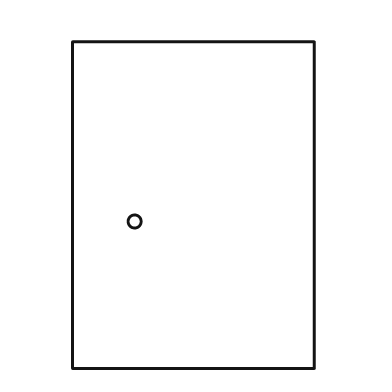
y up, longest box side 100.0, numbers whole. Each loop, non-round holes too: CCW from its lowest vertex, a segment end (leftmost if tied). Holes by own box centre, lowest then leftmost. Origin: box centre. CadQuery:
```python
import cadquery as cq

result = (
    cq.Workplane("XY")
    .moveTo(-37.0, -50.0)
    .lineTo(37.0, -50.0)
    .lineTo(37.0, 50.0)
    .lineTo(-37.0, 50.0)
    .close()
    .moveTo(-18.0, -5.0)
    .circle(2.0)
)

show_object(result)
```